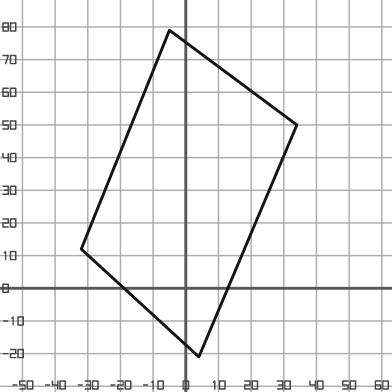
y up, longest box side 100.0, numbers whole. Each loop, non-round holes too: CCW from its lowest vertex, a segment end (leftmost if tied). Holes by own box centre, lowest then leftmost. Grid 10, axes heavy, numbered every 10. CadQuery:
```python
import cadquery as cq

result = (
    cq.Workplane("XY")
    .moveTo(4.0, -21.0)
    .lineTo(34.0, 50.0)
    .lineTo(-5.0, 79.0)
    .lineTo(-32.0, 12.0)
    .close()
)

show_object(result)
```